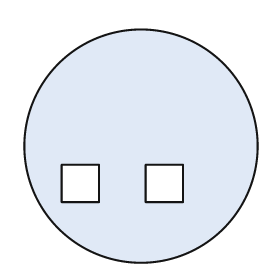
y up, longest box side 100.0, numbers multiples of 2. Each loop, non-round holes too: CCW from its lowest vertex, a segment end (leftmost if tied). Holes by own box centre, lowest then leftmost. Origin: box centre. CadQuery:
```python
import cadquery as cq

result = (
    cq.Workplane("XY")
    .moveTo(0.0, 0.0)
    .circle(50.0)
    .moveTo(-34.0, -24.0)
    .lineTo(-18.0, -24.0)
    .lineTo(-18.0, -8.0)
    .lineTo(-34.0, -8.0)
    .close()
    .moveTo(2.0, -24.0)
    .lineTo(18.0, -24.0)
    .lineTo(18.0, -8.0)
    .lineTo(2.0, -8.0)
    .close()
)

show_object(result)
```